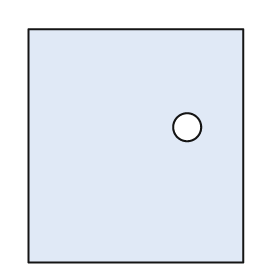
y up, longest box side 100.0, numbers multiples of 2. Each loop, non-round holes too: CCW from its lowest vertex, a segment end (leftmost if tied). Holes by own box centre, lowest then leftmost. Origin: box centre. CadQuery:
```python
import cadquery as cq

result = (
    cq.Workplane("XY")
    .moveTo(-46.0, -50.0)
    .lineTo(46.0, -50.0)
    .lineTo(46.0, 50.0)
    .lineTo(-46.0, 50.0)
    .close()
    .moveTo(22.0, 8.0)
    .circle(6.0)
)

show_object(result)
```